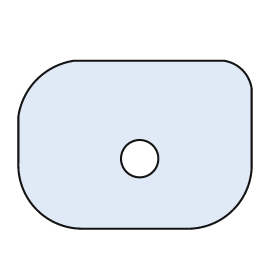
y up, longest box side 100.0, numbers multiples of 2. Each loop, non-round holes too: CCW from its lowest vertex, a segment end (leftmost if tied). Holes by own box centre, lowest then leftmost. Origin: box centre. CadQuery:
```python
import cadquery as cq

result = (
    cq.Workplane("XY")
    .moveTo(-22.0, -36.0)
    .lineTo(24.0, -36.0)
    .threePointArc((42.0, -28.0), (50.0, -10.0))
    .lineTo(50.0, 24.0)
    .threePointArc((46.0, 32.0), (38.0, 36.0))
    .lineTo(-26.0, 36.0)
    .threePointArc((-42.0, 28.0), (-50.0, 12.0))
    .lineTo(-50.0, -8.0)
    .threePointArc((-42.0, -28.0), (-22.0, -36.0))
    .close()
    .moveTo(2.0, -6.0)
    .circle(8.0)
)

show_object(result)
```